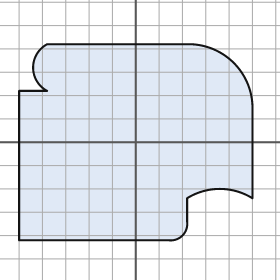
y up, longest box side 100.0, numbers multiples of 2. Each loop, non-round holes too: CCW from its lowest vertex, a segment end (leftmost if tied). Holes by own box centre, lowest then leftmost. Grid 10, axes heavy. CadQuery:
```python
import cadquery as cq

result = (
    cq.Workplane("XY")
    .moveTo(-50.0, -42.0)
    .lineTo(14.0, -42.0)
    .threePointArc((20.0, -40.0), (22.0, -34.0))
    .lineTo(22.0, -24.0)
    .threePointArc((36.0, -20.0), (50.0, -24.0))
    .lineTo(50.0, 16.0)
    .threePointArc((42.0, 34.0), (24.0, 42.0))
    .lineTo(-38.0, 42.0)
    .threePointArc((-44.0, 32.0), (-38.0, 22.0))
    .lineTo(-50.0, 22.0)
    .close()
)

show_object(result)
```